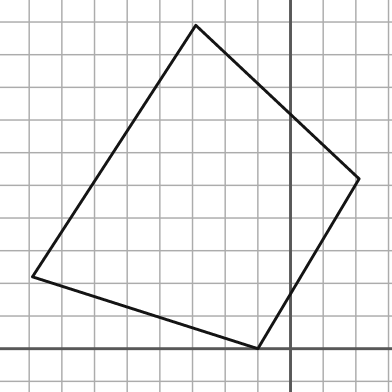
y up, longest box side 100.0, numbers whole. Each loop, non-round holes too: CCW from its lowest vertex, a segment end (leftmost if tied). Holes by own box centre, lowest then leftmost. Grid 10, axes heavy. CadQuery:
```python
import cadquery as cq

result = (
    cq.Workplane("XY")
    .moveTo(-10.0, 0.0)
    .lineTo(21.0, 52.0)
    .lineTo(-29.0, 99.0)
    .lineTo(-79.0, 22.0)
    .close()
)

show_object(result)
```